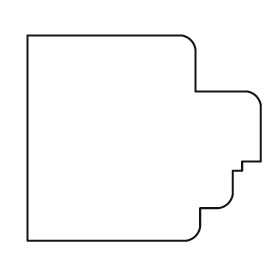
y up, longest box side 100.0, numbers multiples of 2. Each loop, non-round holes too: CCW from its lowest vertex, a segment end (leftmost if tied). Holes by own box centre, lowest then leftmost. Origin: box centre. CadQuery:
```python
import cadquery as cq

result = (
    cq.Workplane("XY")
    .moveTo(-50.0, -44.0)
    .lineTo(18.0, -44.0)
    .threePointArc((22.0, -42.0), (24.0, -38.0))
    .lineTo(24.0, -30.0)
    .lineTo(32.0, -30.0)
    .threePointArc((36.0, -28.0), (38.0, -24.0))
    .lineTo(38.0, -14.0)
    .lineTo(42.0, -14.0)
    .lineTo(42.0, -10.0)
    .lineTo(50.0, -10.0)
    .lineTo(50.0, 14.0)
    .threePointArc((48.0, 18.0), (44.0, 20.0))
    .lineTo(22.0, 20.0)
    .lineTo(22.0, 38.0)
    .threePointArc((20.0, 42.0), (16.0, 44.0))
    .lineTo(-50.0, 44.0)
    .close()
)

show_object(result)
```